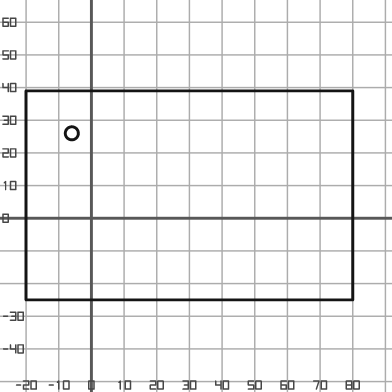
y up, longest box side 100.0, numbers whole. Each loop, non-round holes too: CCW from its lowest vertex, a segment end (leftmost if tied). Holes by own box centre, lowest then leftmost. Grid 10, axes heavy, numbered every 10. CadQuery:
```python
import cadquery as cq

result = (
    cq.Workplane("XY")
    .moveTo(-20.0, -25.0)
    .lineTo(80.0, -25.0)
    .lineTo(80.0, 39.0)
    .lineTo(-20.0, 39.0)
    .close()
    .moveTo(-6.0, 26.0)
    .circle(2.0)
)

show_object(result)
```